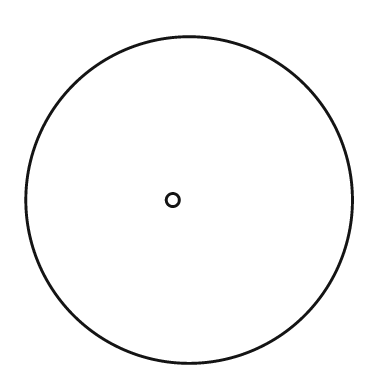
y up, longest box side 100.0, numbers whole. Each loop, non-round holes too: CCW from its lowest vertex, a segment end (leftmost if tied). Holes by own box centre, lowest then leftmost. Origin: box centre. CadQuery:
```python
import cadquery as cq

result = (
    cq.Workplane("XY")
    .moveTo(0.0, 0.0)
    .circle(50.0)
    .moveTo(-5.0, 0.0)
    .circle(2.0)
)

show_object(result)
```